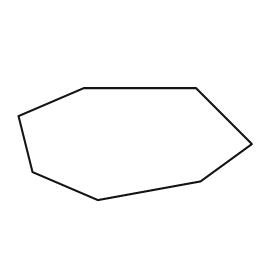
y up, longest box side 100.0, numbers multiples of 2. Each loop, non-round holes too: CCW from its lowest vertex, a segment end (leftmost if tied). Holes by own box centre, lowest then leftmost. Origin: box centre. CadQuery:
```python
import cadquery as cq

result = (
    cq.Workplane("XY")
    .moveTo(-16.0, -24.0)
    .lineTo(28.0, -16.0)
    .lineTo(50.0, 0.0)
    .lineTo(26.0, 24.0)
    .lineTo(-22.0, 24.0)
    .lineTo(-50.0, 12.0)
    .lineTo(-44.0, -12.0)
    .close()
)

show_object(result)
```